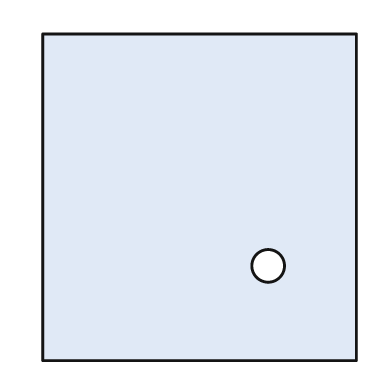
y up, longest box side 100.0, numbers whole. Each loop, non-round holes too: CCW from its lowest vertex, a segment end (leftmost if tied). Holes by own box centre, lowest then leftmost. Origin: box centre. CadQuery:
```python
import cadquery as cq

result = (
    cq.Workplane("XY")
    .moveTo(-48.0, -50.0)
    .lineTo(48.0, -50.0)
    .lineTo(48.0, 50.0)
    .lineTo(-48.0, 50.0)
    .close()
    .moveTo(21.0, -21.0)
    .circle(5.0)
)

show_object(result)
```